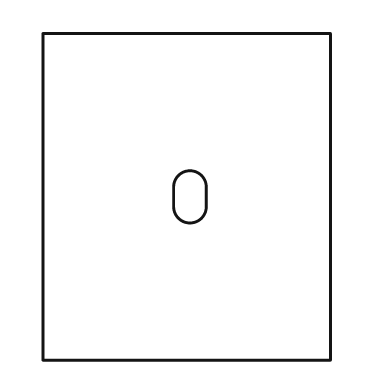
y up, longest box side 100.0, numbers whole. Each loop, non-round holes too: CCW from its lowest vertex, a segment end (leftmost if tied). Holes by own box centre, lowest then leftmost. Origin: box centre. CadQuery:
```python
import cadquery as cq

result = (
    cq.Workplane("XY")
    .moveTo(-44.0, -50.0)
    .lineTo(44.0, -50.0)
    .lineTo(44.0, 50.0)
    .lineTo(-44.0, 50.0)
    .close()
    .moveTo(-4.0, -3.0)
    .threePointArc((1.0, -8.0), (6.0, -3.0))
    .lineTo(6.0, 3.0)
    .threePointArc((1.0, 8.0), (-4.0, 3.0))
    .close()
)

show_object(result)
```